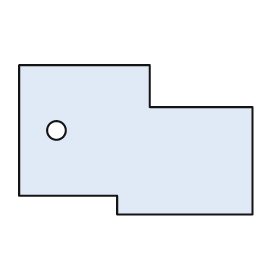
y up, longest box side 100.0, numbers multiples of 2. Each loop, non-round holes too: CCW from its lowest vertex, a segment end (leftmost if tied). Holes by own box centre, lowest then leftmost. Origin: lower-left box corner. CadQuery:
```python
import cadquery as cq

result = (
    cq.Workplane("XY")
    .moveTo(42.0, 0.0)
    .lineTo(100.0, 0.0)
    .lineTo(100.0, 46.0)
    .lineTo(56.0, 46.0)
    .lineTo(56.0, 64.0)
    .lineTo(0.0, 64.0)
    .lineTo(0.0, 8.0)
    .lineTo(42.0, 8.0)
    .close()
    .moveTo(16.0, 36.0)
    .circle(4.0)
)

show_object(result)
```